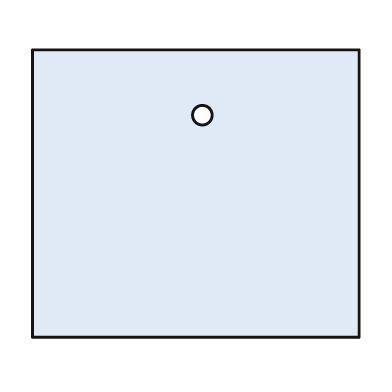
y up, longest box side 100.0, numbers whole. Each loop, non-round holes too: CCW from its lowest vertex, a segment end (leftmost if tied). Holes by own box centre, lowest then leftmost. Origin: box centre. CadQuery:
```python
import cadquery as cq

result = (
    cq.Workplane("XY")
    .moveTo(-50.0, -44.0)
    .lineTo(50.0, -44.0)
    .lineTo(50.0, 44.0)
    .lineTo(-50.0, 44.0)
    .close()
    .moveTo(2.0, 24.0)
    .circle(3.0)
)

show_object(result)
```